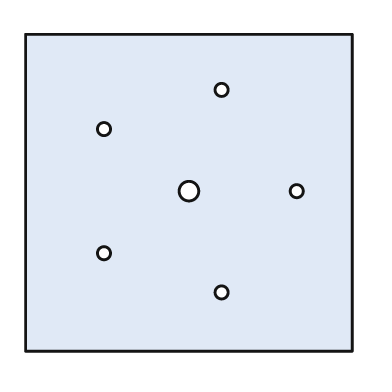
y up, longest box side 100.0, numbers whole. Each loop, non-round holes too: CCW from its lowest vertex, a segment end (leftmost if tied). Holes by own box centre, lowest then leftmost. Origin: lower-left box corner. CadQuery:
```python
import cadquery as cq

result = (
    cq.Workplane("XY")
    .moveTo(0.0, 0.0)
    .lineTo(100.0, 0.0)
    .lineTo(100.0, 97.0)
    .lineTo(0.0, 97.0)
    .close()
    .moveTo(60.0, 18.0)
    .circle(2.0)
    .moveTo(24.0, 30.0)
    .circle(2.0)
    .moveTo(50.0, 49.0)
    .circle(3.0)
    .moveTo(83.0, 49.0)
    .circle(2.0)
    .moveTo(24.0, 68.0)
    .circle(2.0)
    .moveTo(60.0, 80.0)
    .circle(2.0)
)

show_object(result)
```